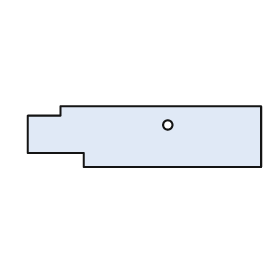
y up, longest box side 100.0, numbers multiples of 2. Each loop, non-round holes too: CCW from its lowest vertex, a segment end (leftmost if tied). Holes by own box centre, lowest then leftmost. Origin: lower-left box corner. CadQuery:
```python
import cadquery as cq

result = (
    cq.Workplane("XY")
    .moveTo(24.0, 0.0)
    .lineTo(100.0, 0.0)
    .lineTo(100.0, 26.0)
    .lineTo(14.0, 26.0)
    .lineTo(14.0, 22.0)
    .lineTo(0.0, 22.0)
    .lineTo(0.0, 6.0)
    .lineTo(24.0, 6.0)
    .close()
    .moveTo(60.0, 18.0)
    .circle(2.0)
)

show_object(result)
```